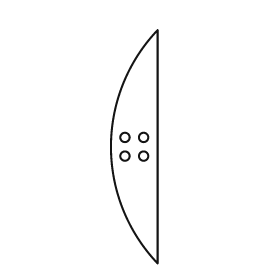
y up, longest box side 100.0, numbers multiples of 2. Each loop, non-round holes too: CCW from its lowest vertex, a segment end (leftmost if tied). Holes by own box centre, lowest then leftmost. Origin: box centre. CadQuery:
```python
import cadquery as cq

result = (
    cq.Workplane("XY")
    .moveTo(10.0, -50.0)
    .lineTo(10.0, 50.0)
    .threePointArc((-10.0, 0.0), (10.0, -50.0))
    .close()
    .moveTo(-4.0, -4.0)
    .circle(2.0)
    .moveTo(4.0, -4.0)
    .circle(2.0)
    .moveTo(-4.0, 4.0)
    .circle(2.0)
    .moveTo(4.0, 4.0)
    .circle(2.0)
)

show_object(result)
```